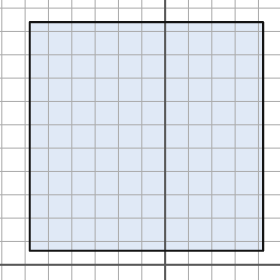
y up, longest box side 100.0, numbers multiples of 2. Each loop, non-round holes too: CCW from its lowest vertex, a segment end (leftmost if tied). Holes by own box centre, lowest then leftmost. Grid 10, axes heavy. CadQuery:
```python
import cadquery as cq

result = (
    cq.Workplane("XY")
    .moveTo(-58.0, 6.0)
    .lineTo(42.0, 6.0)
    .lineTo(42.0, 104.0)
    .lineTo(-58.0, 104.0)
    .close()
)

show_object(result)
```